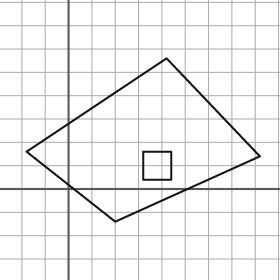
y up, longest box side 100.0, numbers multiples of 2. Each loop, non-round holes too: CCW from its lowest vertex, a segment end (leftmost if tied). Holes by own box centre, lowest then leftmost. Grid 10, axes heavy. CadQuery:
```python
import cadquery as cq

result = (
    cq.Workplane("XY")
    .moveTo(20.0, -14.0)
    .lineTo(82.0, 14.0)
    .lineTo(42.0, 56.0)
    .lineTo(-18.0, 16.0)
    .close()
    .moveTo(32.0, 4.0)
    .lineTo(44.0, 4.0)
    .lineTo(44.0, 16.0)
    .lineTo(32.0, 16.0)
    .close()
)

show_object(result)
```